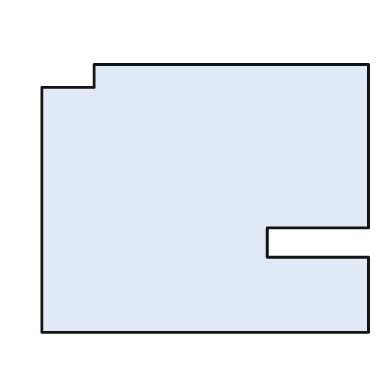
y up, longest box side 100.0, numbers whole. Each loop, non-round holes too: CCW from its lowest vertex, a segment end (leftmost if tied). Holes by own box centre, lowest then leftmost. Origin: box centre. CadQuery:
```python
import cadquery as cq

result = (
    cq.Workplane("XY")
    .moveTo(-50.0, -41.0)
    .lineTo(50.0, -41.0)
    .lineTo(50.0, -18.0)
    .lineTo(19.0, -18.0)
    .lineTo(19.0, -9.0)
    .lineTo(50.0, -9.0)
    .lineTo(50.0, 41.0)
    .lineTo(-34.0, 41.0)
    .lineTo(-34.0, 34.0)
    .lineTo(-50.0, 34.0)
    .close()
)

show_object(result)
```